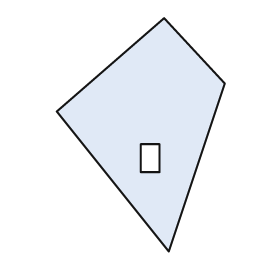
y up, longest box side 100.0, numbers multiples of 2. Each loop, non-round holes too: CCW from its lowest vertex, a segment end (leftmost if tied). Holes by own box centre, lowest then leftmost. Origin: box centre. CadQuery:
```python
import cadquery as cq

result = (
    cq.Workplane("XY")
    .moveTo(12.0, -50.0)
    .lineTo(36.0, 22.0)
    .lineTo(10.0, 50.0)
    .lineTo(-36.0, 10.0)
    .close()
    .moveTo(0.0, -16.0)
    .lineTo(8.0, -16.0)
    .lineTo(8.0, -4.0)
    .lineTo(0.0, -4.0)
    .close()
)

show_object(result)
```